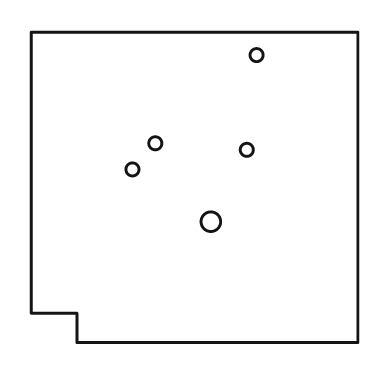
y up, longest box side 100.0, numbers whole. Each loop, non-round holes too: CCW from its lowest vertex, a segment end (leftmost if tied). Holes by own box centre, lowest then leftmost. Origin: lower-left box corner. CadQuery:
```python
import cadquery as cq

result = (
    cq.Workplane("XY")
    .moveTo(14.0, 0.0)
    .lineTo(100.0, 0.0)
    .lineTo(100.0, 95.0)
    .lineTo(0.0, 95.0)
    .lineTo(0.0, 9.0)
    .lineTo(14.0, 9.0)
    .close()
    .moveTo(55.0, 37.0)
    .circle(3.0)
    .moveTo(31.0, 53.0)
    .circle(2.0)
    .moveTo(66.0, 59.0)
    .circle(2.0)
    .moveTo(38.0, 61.0)
    .circle(2.0)
    .moveTo(69.0, 88.0)
    .circle(2.0)
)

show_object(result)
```